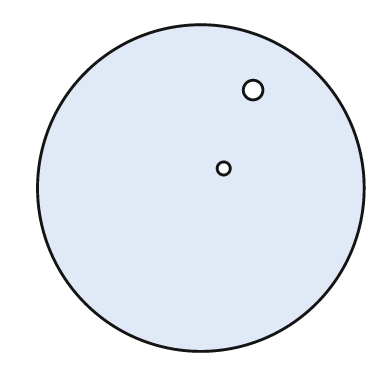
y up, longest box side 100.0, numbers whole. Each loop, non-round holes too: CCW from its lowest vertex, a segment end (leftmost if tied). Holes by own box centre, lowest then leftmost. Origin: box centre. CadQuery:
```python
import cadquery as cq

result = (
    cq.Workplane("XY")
    .moveTo(0.0, 0.0)
    .circle(50.0)
    .moveTo(7.0, 6.0)
    .circle(2.0)
    .moveTo(16.0, 30.0)
    .circle(3.0)
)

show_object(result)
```